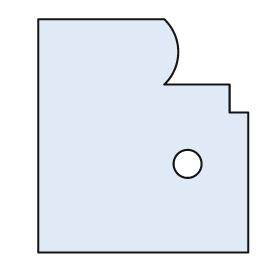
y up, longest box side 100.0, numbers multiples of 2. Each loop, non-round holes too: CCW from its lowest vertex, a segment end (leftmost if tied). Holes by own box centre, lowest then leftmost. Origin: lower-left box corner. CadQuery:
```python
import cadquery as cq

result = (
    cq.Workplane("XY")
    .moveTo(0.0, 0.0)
    .lineTo(90.0, 0.0)
    .lineTo(90.0, 60.0)
    .lineTo(82.0, 60.0)
    .lineTo(82.0, 72.0)
    .lineTo(54.0, 72.0)
    .threePointArc((60.0, 86.0), (54.0, 100.0))
    .lineTo(0.0, 100.0)
    .close()
    .moveTo(64.0, 38.0)
    .circle(6.0)
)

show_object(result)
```